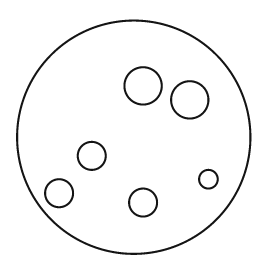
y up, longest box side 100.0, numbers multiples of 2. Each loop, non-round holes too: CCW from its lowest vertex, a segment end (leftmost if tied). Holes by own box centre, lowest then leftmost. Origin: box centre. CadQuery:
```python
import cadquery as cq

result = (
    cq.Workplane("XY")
    .moveTo(0.0, 0.0)
    .circle(50.0)
    .moveTo(4.0, -28.0)
    .circle(6.0)
    .moveTo(-32.0, -24.0)
    .circle(6.0)
    .moveTo(32.0, -18.0)
    .circle(4.0)
    .moveTo(-18.0, -8.0)
    .circle(6.0)
    .moveTo(24.0, 16.0)
    .circle(8.0)
    .moveTo(4.0, 22.0)
    .circle(8.0)
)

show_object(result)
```